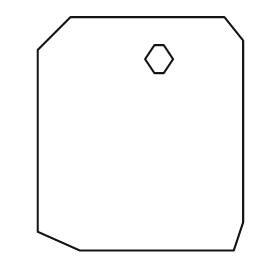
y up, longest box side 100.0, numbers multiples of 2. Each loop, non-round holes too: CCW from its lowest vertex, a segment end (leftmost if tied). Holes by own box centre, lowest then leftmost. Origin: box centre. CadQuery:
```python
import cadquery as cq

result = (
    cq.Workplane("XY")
    .moveTo(-26.0, -50.0)
    .lineTo(40.0, -50.0)
    .lineTo(44.0, -38.0)
    .lineTo(44.0, 40.0)
    .lineTo(36.0, 50.0)
    .lineTo(-30.0, 50.0)
    .lineTo(-44.0, 36.0)
    .lineTo(-44.0, -42.0)
    .close()
    .moveTo(6.0, 26.0)
    .lineTo(10.0, 26.0)
    .lineTo(14.0, 32.0)
    .lineTo(10.0, 38.0)
    .lineTo(6.0, 38.0)
    .lineTo(2.0, 32.0)
    .close()
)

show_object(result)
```